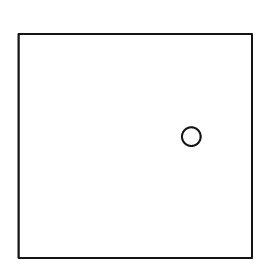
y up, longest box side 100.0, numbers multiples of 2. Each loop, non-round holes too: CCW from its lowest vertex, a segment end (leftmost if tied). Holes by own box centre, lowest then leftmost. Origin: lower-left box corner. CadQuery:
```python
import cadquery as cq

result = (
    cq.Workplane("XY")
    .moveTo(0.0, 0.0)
    .lineTo(100.0, 0.0)
    .lineTo(100.0, 96.0)
    .lineTo(0.0, 96.0)
    .close()
    .moveTo(74.0, 52.0)
    .circle(4.0)
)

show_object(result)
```